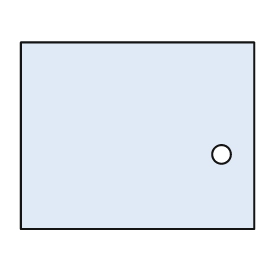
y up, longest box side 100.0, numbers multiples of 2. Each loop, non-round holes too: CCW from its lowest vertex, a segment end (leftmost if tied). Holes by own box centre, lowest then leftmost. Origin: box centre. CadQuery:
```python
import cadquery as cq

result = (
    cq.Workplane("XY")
    .moveTo(-50.0, -40.0)
    .lineTo(50.0, -40.0)
    .lineTo(50.0, 40.0)
    .lineTo(-50.0, 40.0)
    .close()
    .moveTo(36.0, -8.0)
    .circle(4.0)
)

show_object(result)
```